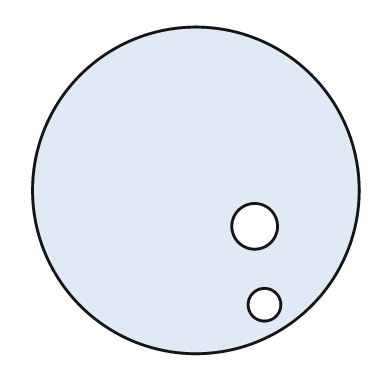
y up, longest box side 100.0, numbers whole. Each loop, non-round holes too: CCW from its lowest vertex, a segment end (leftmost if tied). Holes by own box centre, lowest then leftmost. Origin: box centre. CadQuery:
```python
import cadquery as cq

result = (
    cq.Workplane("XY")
    .moveTo(0.0, 0.0)
    .circle(50.0)
    .moveTo(21.0, -35.0)
    .circle(5.0)
    .moveTo(18.0, -11.0)
    .circle(7.0)
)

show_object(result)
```